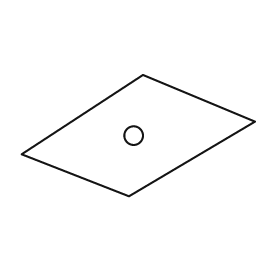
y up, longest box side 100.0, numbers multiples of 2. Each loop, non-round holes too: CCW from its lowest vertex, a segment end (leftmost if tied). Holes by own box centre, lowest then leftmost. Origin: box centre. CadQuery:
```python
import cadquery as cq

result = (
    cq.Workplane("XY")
    .moveTo(-4.0, -26.0)
    .lineTo(50.0, 6.0)
    .lineTo(2.0, 26.0)
    .lineTo(-50.0, -8.0)
    .close()
    .moveTo(-2.0, 0.0)
    .circle(4.0)
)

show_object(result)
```